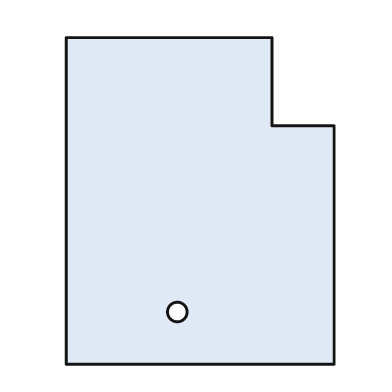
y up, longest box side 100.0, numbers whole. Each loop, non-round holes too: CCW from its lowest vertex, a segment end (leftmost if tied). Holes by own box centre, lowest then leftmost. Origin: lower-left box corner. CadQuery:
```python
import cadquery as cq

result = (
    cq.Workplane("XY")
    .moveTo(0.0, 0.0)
    .lineTo(82.0, 0.0)
    .lineTo(82.0, 73.0)
    .lineTo(63.0, 73.0)
    .lineTo(63.0, 100.0)
    .lineTo(0.0, 100.0)
    .close()
    .moveTo(34.0, 16.0)
    .circle(3.0)
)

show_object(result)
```